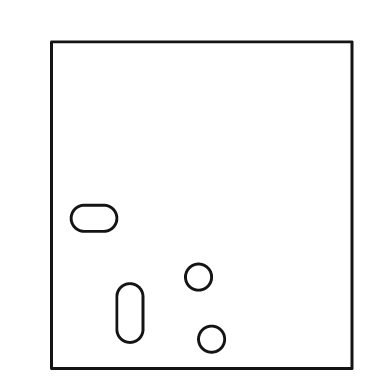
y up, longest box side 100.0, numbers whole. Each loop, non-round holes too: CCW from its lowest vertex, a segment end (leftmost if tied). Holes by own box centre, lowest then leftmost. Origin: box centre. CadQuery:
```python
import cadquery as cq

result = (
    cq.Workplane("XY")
    .moveTo(-46.0, -50.0)
    .lineTo(46.0, -50.0)
    .lineTo(46.0, 50.0)
    .lineTo(-46.0, 50.0)
    .close()
    .moveTo(3.0, -41.0)
    .circle(4.0)
    .moveTo(-26.0, -38.0)
    .threePointArc((-22.0, -42.0), (-18.0, -38.0))
    .lineTo(-18.0, -28.0)
    .threePointArc((-22.0, -24.0), (-26.0, -28.0))
    .close()
    .moveTo(-1.0, -22.0)
    .circle(4.0)
    .moveTo(-36.0, -8.0)
    .lineTo(-30.0, -8.0)
    .threePointArc((-26.0, -4.0), (-30.0, 0.0))
    .lineTo(-36.0, 0.0)
    .threePointArc((-40.0, -4.0), (-36.0, -8.0))
    .close()
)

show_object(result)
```